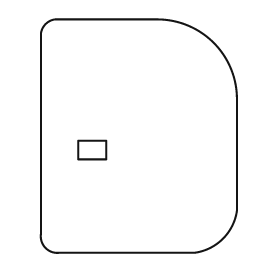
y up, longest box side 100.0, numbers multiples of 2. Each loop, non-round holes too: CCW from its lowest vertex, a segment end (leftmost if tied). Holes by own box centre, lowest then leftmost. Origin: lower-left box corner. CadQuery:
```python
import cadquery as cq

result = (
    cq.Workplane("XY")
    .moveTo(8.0, 0.0)
    .lineTo(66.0, 0.0)
    .threePointArc((78.0, 6.0), (84.0, 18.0))
    .lineTo(84.0, 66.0)
    .threePointArc((74.0, 90.0), (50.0, 100.0))
    .lineTo(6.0, 100.0)
    .threePointArc((2.0, 98.0), (0.0, 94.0))
    .lineTo(0.0, 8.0)
    .threePointArc((2.0, 2.0), (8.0, 0.0))
    .close()
    .moveTo(16.0, 40.0)
    .lineTo(28.0, 40.0)
    .lineTo(28.0, 48.0)
    .lineTo(16.0, 48.0)
    .close()
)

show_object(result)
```